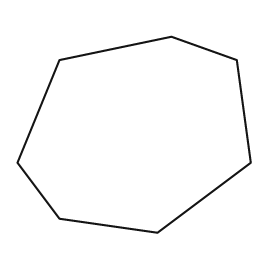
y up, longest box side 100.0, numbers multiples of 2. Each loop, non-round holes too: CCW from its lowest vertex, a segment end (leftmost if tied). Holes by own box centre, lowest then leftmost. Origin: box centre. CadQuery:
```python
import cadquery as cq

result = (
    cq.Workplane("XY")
    .moveTo(10.0, -42.0)
    .lineTo(50.0, -12.0)
    .lineTo(44.0, 32.0)
    .lineTo(16.0, 42.0)
    .lineTo(-32.0, 32.0)
    .lineTo(-50.0, -12.0)
    .lineTo(-32.0, -36.0)
    .close()
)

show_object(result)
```